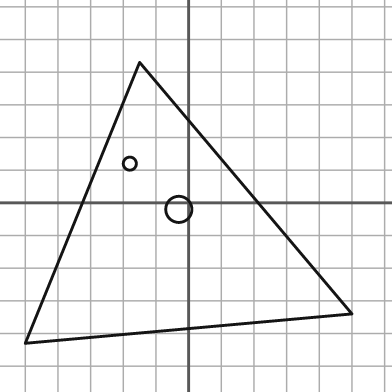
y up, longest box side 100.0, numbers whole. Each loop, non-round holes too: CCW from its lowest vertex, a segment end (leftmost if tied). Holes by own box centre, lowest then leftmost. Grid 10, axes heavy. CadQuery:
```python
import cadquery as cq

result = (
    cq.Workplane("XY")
    .moveTo(-50.0, -43.0)
    .lineTo(50.0, -34.0)
    .lineTo(-15.0, 43.0)
    .close()
    .moveTo(-3.0, -2.0)
    .circle(4.0)
    .moveTo(-18.0, 12.0)
    .circle(2.0)
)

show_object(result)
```